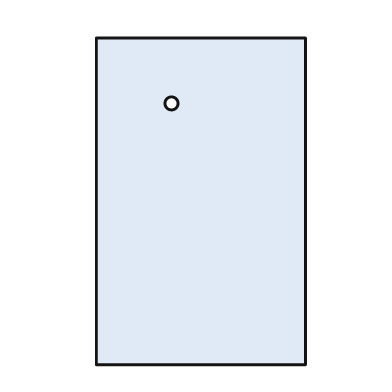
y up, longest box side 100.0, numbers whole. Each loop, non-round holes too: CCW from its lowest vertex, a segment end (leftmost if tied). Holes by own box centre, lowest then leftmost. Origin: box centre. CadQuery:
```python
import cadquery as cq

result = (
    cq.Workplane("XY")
    .moveTo(-32.0, -50.0)
    .lineTo(32.0, -50.0)
    .lineTo(32.0, 50.0)
    .lineTo(-32.0, 50.0)
    .close()
    .moveTo(-9.0, 30.0)
    .circle(2.0)
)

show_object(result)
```